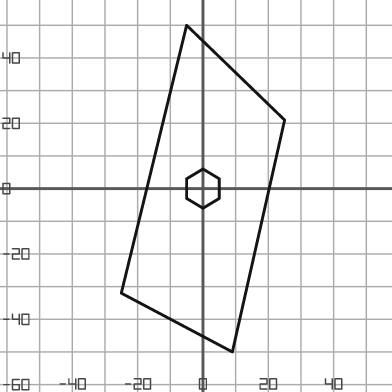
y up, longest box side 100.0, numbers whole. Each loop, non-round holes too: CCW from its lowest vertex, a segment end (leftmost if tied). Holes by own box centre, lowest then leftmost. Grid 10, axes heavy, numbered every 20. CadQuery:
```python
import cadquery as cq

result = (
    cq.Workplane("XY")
    .moveTo(9.0, -50.0)
    .lineTo(25.0, 21.0)
    .lineTo(-5.0, 50.0)
    .lineTo(-25.0, -32.0)
    .close()
    .moveTo(0.0, -6.0)
    .lineTo(5.0, -3.0)
    .lineTo(5.0, 3.0)
    .lineTo(0.0, 6.0)
    .lineTo(-5.0, 3.0)
    .lineTo(-5.0, -3.0)
    .close()
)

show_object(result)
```